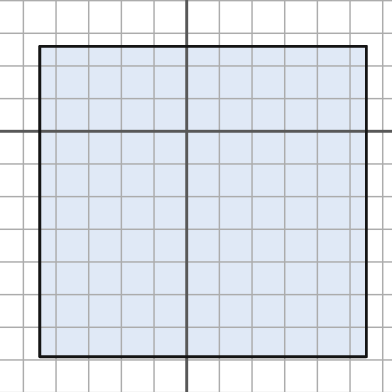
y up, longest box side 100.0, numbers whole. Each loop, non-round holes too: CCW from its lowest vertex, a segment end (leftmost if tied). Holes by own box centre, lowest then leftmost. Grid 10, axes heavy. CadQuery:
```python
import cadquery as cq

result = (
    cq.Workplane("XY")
    .moveTo(-45.0, -69.0)
    .lineTo(55.0, -69.0)
    .lineTo(55.0, 26.0)
    .lineTo(-45.0, 26.0)
    .close()
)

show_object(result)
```